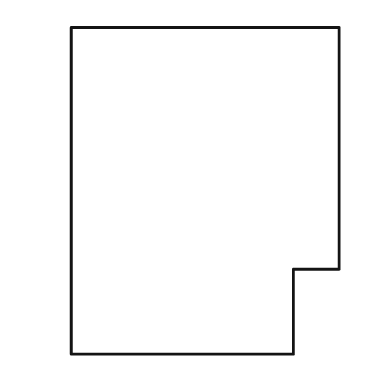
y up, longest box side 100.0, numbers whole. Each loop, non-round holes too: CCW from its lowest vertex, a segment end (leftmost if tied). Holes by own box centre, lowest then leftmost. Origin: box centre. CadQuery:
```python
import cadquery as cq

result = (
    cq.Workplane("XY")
    .moveTo(-41.0, -50.0)
    .lineTo(27.0, -50.0)
    .lineTo(27.0, -24.0)
    .lineTo(41.0, -24.0)
    .lineTo(41.0, 50.0)
    .lineTo(-41.0, 50.0)
    .close()
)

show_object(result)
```